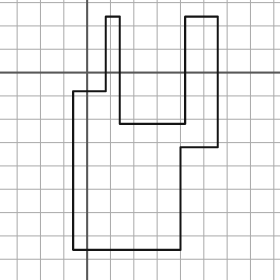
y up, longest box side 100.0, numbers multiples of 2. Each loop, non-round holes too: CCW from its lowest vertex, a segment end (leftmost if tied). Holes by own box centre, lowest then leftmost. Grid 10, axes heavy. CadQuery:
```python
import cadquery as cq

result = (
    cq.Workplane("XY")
    .moveTo(-6.0, -76.0)
    .lineTo(40.0, -76.0)
    .lineTo(40.0, -32.0)
    .lineTo(56.0, -32.0)
    .lineTo(56.0, 24.0)
    .lineTo(42.0, 24.0)
    .lineTo(42.0, -22.0)
    .lineTo(14.0, -22.0)
    .lineTo(14.0, 24.0)
    .lineTo(8.0, 24.0)
    .lineTo(8.0, -8.0)
    .lineTo(-6.0, -8.0)
    .close()
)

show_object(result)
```